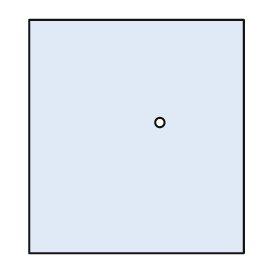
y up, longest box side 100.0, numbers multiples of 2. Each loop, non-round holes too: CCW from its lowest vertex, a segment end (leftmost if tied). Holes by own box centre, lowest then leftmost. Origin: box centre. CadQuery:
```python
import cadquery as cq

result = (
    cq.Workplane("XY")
    .moveTo(-46.0, -50.0)
    .lineTo(46.0, -50.0)
    .lineTo(46.0, 50.0)
    .lineTo(-46.0, 50.0)
    .close()
    .moveTo(10.0, 6.0)
    .circle(2.0)
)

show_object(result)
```